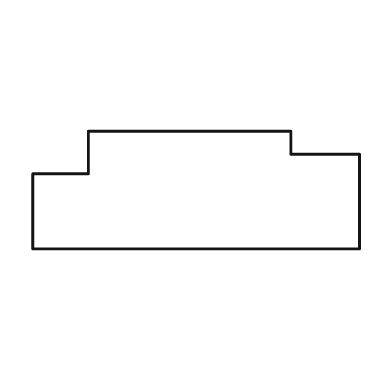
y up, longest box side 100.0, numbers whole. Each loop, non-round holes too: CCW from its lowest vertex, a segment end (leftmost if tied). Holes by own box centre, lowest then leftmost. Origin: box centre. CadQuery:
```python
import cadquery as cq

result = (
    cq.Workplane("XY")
    .moveTo(-50.0, -18.0)
    .lineTo(50.0, -18.0)
    .lineTo(50.0, 11.0)
    .lineTo(29.0, 11.0)
    .lineTo(29.0, 18.0)
    .lineTo(-33.0, 18.0)
    .lineTo(-33.0, 5.0)
    .lineTo(-50.0, 5.0)
    .close()
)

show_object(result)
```